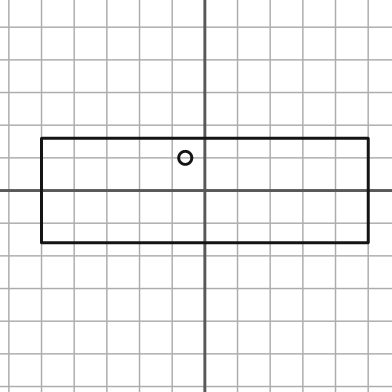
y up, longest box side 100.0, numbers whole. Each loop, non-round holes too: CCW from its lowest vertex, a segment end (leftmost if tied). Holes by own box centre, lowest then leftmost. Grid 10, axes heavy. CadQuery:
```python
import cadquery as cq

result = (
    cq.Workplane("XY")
    .moveTo(-50.0, -16.0)
    .lineTo(50.0, -16.0)
    .lineTo(50.0, 16.0)
    .lineTo(-50.0, 16.0)
    .close()
    .moveTo(-6.0, 10.0)
    .circle(2.0)
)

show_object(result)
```